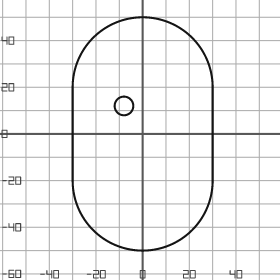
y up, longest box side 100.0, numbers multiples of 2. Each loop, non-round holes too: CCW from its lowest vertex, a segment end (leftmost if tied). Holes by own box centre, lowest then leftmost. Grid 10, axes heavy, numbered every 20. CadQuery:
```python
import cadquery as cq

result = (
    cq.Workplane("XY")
    .moveTo(-30.0, -20.0)
    .threePointArc((0.0, -50.0), (30.0, -20.0))
    .lineTo(30.0, 20.0)
    .threePointArc((0.0, 50.0), (-30.0, 20.0))
    .close()
    .moveTo(-8.0, 12.0)
    .circle(4.0)
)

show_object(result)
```